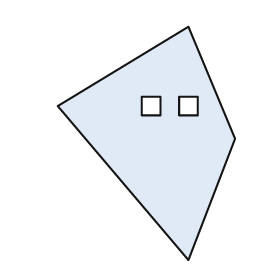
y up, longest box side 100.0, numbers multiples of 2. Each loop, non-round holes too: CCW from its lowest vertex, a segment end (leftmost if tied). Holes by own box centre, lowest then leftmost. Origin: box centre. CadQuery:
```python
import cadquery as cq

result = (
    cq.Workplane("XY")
    .moveTo(18.0, -50.0)
    .lineTo(38.0, 2.0)
    .lineTo(18.0, 50.0)
    .lineTo(-38.0, 16.0)
    .close()
    .moveTo(-2.0, 12.0)
    .lineTo(6.0, 12.0)
    .lineTo(6.0, 20.0)
    .lineTo(-2.0, 20.0)
    .close()
    .moveTo(14.0, 12.0)
    .lineTo(22.0, 12.0)
    .lineTo(22.0, 20.0)
    .lineTo(14.0, 20.0)
    .close()
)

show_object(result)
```